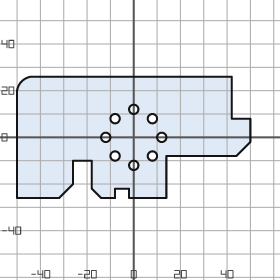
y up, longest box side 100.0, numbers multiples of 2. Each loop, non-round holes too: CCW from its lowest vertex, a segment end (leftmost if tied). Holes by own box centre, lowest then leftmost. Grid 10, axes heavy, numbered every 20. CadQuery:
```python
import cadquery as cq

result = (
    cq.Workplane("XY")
    .moveTo(-50.0, -26.0)
    .lineTo(-32.0, -26.0)
    .lineTo(-26.0, -20.0)
    .lineTo(-26.0, -10.0)
    .lineTo(-18.0, -10.0)
    .lineTo(-18.0, -22.0)
    .lineTo(-14.0, -26.0)
    .lineTo(-8.0, -26.0)
    .lineTo(-8.0, -22.0)
    .lineTo(-2.0, -22.0)
    .lineTo(-2.0, -26.0)
    .lineTo(14.0, -26.0)
    .lineTo(14.0, -8.0)
    .lineTo(44.0, -8.0)
    .lineTo(50.0, -2.0)
    .lineTo(50.0, 8.0)
    .lineTo(42.0, 8.0)
    .lineTo(42.0, 26.0)
    .lineTo(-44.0, 26.0)
    .threePointArc((-48.0, 24.0), (-50.0, 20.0))
    .close()
    .moveTo(0.0, -12.0)
    .circle(2.0)
    .moveTo(-8.0, -8.0)
    .circle(2.0)
    .moveTo(8.0, -8.0)
    .circle(2.0)
    .moveTo(-12.0, 0.0)
    .circle(2.0)
    .moveTo(12.0, 0.0)
    .circle(2.0)
    .moveTo(-8.0, 8.0)
    .circle(2.0)
    .moveTo(8.0, 8.0)
    .circle(2.0)
    .moveTo(0.0, 12.0)
    .circle(2.0)
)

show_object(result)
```